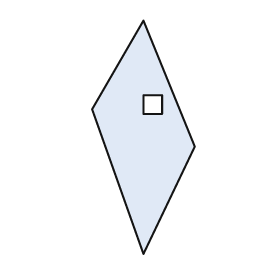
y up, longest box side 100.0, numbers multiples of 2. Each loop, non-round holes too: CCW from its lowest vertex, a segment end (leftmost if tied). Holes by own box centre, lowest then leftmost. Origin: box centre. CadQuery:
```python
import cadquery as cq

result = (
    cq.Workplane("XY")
    .moveTo(0.0, -50.0)
    .lineTo(22.0, -4.0)
    .lineTo(0.0, 50.0)
    .lineTo(-22.0, 12.0)
    .close()
    .moveTo(0.0, 10.0)
    .lineTo(8.0, 10.0)
    .lineTo(8.0, 18.0)
    .lineTo(0.0, 18.0)
    .close()
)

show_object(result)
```